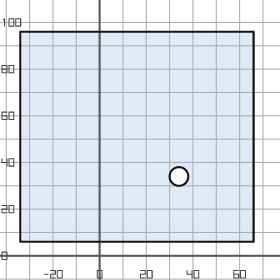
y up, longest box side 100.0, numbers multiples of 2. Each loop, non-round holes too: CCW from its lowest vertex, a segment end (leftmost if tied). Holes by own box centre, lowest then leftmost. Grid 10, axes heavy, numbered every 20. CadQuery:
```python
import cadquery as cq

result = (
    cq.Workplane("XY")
    .moveTo(-34.0, 6.0)
    .lineTo(66.0, 6.0)
    .lineTo(66.0, 96.0)
    .lineTo(-34.0, 96.0)
    .close()
    .moveTo(34.0, 34.0)
    .circle(4.0)
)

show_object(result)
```